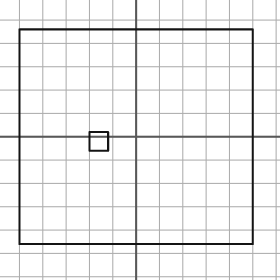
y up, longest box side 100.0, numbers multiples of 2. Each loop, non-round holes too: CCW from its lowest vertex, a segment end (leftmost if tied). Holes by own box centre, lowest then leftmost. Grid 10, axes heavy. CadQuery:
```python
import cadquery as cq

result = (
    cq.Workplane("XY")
    .moveTo(-50.0, -46.0)
    .lineTo(50.0, -46.0)
    .lineTo(50.0, 46.0)
    .lineTo(-50.0, 46.0)
    .close()
    .moveTo(-20.0, -6.0)
    .lineTo(-12.0, -6.0)
    .lineTo(-12.0, 2.0)
    .lineTo(-20.0, 2.0)
    .close()
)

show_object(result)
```